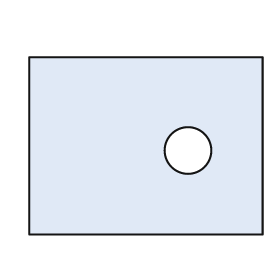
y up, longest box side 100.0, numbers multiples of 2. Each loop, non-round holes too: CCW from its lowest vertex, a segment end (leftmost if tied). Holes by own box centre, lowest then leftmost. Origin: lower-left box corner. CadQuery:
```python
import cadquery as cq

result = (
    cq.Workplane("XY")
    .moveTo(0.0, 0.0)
    .lineTo(100.0, 0.0)
    .lineTo(100.0, 76.0)
    .lineTo(0.0, 76.0)
    .close()
    .moveTo(68.0, 36.0)
    .circle(10.0)
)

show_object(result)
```